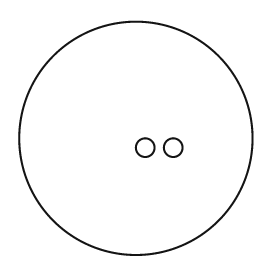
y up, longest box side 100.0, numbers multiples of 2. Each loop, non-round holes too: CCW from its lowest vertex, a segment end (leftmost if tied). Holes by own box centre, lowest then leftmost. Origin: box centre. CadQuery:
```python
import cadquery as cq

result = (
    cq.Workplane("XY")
    .moveTo(0.0, 0.0)
    .circle(50.0)
    .moveTo(4.0, -4.0)
    .circle(4.0)
    .moveTo(16.0, -4.0)
    .circle(4.0)
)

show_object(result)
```